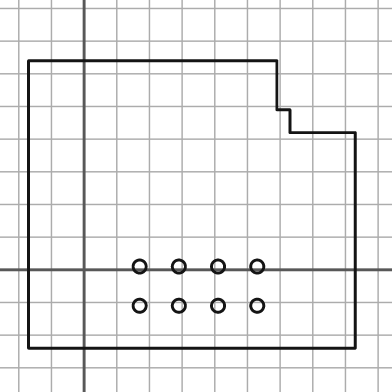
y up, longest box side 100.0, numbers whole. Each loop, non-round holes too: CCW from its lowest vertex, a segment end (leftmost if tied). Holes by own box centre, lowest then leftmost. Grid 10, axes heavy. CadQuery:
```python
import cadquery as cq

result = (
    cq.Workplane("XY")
    .moveTo(-17.0, -24.0)
    .lineTo(83.0, -24.0)
    .lineTo(83.0, 42.0)
    .lineTo(63.0, 42.0)
    .lineTo(63.0, 49.0)
    .lineTo(59.0, 49.0)
    .lineTo(59.0, 64.0)
    .lineTo(-17.0, 64.0)
    .close()
    .moveTo(17.0, -11.0)
    .circle(2.0)
    .moveTo(29.0, -11.0)
    .circle(2.0)
    .moveTo(41.0, -11.0)
    .circle(2.0)
    .moveTo(53.0, -11.0)
    .circle(2.0)
    .moveTo(17.0, 1.0)
    .circle(2.0)
    .moveTo(29.0, 1.0)
    .circle(2.0)
    .moveTo(41.0, 1.0)
    .circle(2.0)
    .moveTo(53.0, 1.0)
    .circle(2.0)
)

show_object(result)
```